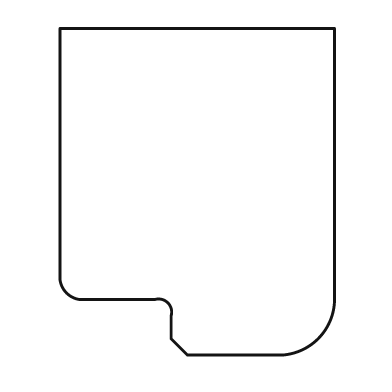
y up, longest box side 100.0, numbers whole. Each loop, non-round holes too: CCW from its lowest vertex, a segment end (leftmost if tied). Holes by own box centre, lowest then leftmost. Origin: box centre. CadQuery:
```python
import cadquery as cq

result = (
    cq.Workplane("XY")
    .moveTo(-3.0, -50.0)
    .lineTo(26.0, -50.0)
    .threePointArc((37.0, -45.0), (42.0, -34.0))
    .lineTo(42.0, 50.0)
    .lineTo(-42.0, 50.0)
    .lineTo(-42.0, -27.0)
    .threePointArc((-40.0, -31.0), (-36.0, -33.0))
    .lineTo(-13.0, -33.0)
    .threePointArc((-9.0, -34.0), (-8.0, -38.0))
    .lineTo(-8.0, -45.0)
    .close()
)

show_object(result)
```